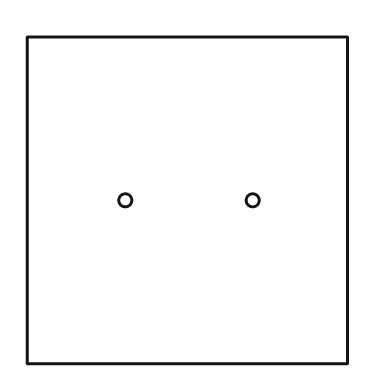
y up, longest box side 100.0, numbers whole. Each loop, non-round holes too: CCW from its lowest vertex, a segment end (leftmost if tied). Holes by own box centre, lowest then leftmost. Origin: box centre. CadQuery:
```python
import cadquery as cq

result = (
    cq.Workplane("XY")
    .moveTo(-49.0, -50.0)
    .lineTo(49.0, -50.0)
    .lineTo(49.0, 50.0)
    .lineTo(-49.0, 50.0)
    .close()
    .moveTo(-19.0, 0.0)
    .circle(2.0)
    .moveTo(20.0, 0.0)
    .circle(2.0)
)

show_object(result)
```